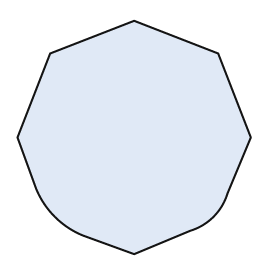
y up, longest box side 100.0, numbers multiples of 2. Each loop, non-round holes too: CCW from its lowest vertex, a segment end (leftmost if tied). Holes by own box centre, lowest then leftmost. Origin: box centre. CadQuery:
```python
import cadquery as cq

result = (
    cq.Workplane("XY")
    .moveTo(0.0, -50.0)
    .lineTo(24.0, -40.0)
    .threePointArc((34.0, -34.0), (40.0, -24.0))
    .lineTo(50.0, 0.0)
    .lineTo(36.0, 36.0)
    .lineTo(0.0, 50.0)
    .lineTo(-36.0, 36.0)
    .lineTo(-50.0, 0.0)
    .lineTo(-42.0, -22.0)
    .threePointArc((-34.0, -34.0), (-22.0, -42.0))
    .close()
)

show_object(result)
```